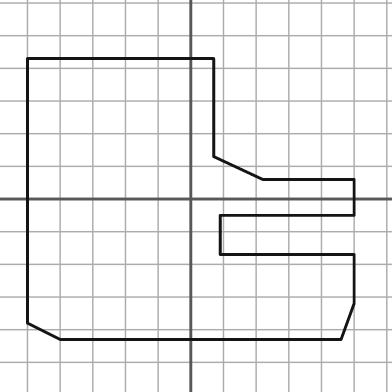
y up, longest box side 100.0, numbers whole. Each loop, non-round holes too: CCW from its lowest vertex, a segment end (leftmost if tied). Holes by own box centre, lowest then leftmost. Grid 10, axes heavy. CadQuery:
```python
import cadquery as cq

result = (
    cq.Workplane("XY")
    .moveTo(-40.0, -43.0)
    .lineTo(46.0, -43.0)
    .lineTo(50.0, -32.0)
    .lineTo(50.0, -17.0)
    .lineTo(9.0, -17.0)
    .lineTo(9.0, -5.0)
    .lineTo(50.0, -5.0)
    .lineTo(50.0, 6.0)
    .lineTo(22.0, 6.0)
    .lineTo(7.0, 13.0)
    .lineTo(7.0, 43.0)
    .lineTo(-50.0, 43.0)
    .lineTo(-50.0, -38.0)
    .close()
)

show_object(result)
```